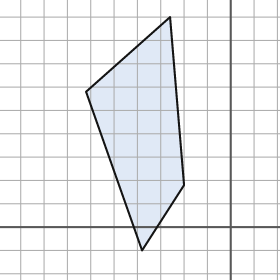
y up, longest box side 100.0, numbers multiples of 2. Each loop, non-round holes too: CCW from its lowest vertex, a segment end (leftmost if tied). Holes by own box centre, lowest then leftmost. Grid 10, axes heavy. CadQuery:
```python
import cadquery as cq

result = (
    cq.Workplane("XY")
    .moveTo(-38.0, -10.0)
    .lineTo(-20.0, 18.0)
    .lineTo(-26.0, 90.0)
    .lineTo(-62.0, 58.0)
    .close()
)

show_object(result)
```